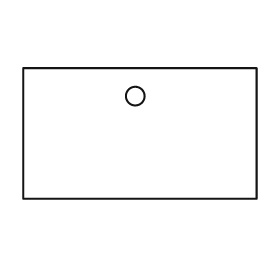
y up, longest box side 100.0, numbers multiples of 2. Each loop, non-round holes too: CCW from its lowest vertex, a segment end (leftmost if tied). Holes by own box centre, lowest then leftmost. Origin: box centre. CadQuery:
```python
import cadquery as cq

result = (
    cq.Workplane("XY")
    .moveTo(-50.0, -28.0)
    .lineTo(50.0, -28.0)
    .lineTo(50.0, 28.0)
    .lineTo(-50.0, 28.0)
    .close()
    .moveTo(-2.0, 16.0)
    .circle(4.0)
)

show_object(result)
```